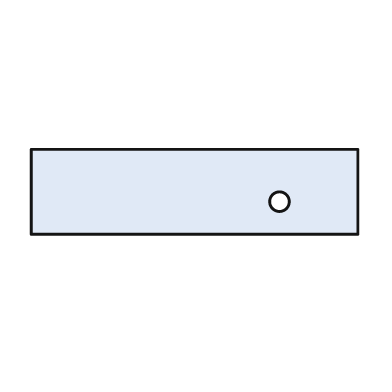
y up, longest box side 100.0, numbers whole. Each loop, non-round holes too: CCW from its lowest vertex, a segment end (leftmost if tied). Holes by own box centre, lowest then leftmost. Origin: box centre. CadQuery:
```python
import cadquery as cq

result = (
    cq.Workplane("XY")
    .moveTo(-50.0, -13.0)
    .lineTo(50.0, -13.0)
    .lineTo(50.0, 13.0)
    .lineTo(-50.0, 13.0)
    .close()
    .moveTo(26.0, -3.0)
    .circle(3.0)
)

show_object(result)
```